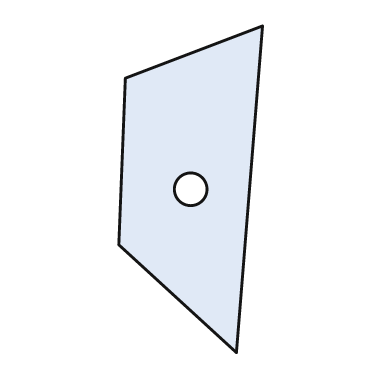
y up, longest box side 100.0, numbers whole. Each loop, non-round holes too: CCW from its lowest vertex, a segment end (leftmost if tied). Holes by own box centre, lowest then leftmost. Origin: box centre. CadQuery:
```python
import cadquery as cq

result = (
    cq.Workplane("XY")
    .moveTo(14.0, -50.0)
    .lineTo(22.0, 50.0)
    .lineTo(-20.0, 34.0)
    .lineTo(-22.0, -17.0)
    .close()
    .moveTo(0.0, 0.0)
    .circle(5.0)
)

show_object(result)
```